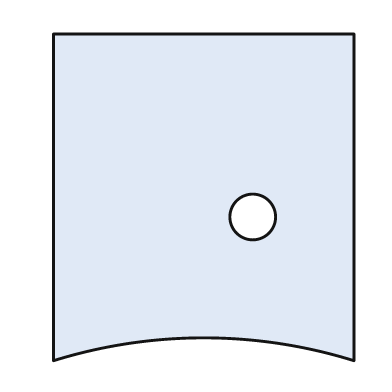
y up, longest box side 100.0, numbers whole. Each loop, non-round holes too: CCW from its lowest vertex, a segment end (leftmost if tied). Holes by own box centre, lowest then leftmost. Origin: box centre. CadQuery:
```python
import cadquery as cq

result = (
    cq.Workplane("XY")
    .moveTo(-46.0, -50.0)
    .threePointArc((0.0, -43.0), (46.0, -50.0))
    .lineTo(46.0, 50.0)
    .lineTo(-46.0, 50.0)
    .close()
    .moveTo(15.0, -6.0)
    .circle(7.0)
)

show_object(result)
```